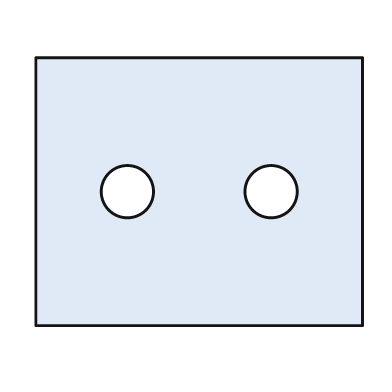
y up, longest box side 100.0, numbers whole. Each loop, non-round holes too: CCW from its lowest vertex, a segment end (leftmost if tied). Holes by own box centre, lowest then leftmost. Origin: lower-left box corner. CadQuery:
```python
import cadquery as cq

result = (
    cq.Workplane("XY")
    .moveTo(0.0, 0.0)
    .lineTo(100.0, 0.0)
    .lineTo(100.0, 82.0)
    .lineTo(0.0, 82.0)
    .close()
    .moveTo(28.0, 41.0)
    .circle(8.0)
    .moveTo(72.0, 41.0)
    .circle(8.0)
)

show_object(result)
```